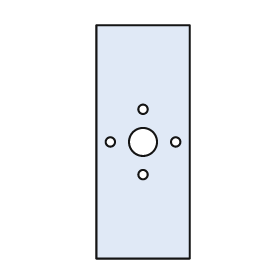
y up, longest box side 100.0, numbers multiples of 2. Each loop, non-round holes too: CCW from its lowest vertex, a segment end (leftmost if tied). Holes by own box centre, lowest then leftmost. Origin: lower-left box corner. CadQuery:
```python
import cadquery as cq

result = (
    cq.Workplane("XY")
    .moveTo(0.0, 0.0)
    .lineTo(40.0, 0.0)
    .lineTo(40.0, 100.0)
    .lineTo(0.0, 100.0)
    .close()
    .moveTo(20.0, 36.0)
    .circle(2.0)
    .moveTo(6.0, 50.0)
    .circle(2.0)
    .moveTo(20.0, 50.0)
    .circle(6.0)
    .moveTo(34.0, 50.0)
    .circle(2.0)
    .moveTo(20.0, 64.0)
    .circle(2.0)
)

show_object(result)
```